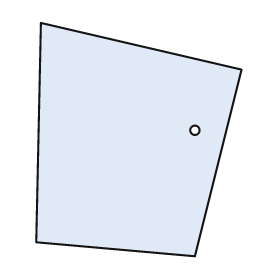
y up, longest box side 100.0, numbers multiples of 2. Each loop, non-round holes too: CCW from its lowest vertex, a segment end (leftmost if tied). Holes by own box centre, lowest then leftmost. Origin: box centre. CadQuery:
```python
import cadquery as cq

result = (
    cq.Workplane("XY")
    .moveTo(24.0, -50.0)
    .lineTo(44.0, 30.0)
    .lineTo(-42.0, 50.0)
    .lineTo(-44.0, -44.0)
    .close()
    .moveTo(24.0, 4.0)
    .circle(2.0)
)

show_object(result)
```